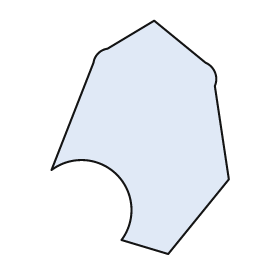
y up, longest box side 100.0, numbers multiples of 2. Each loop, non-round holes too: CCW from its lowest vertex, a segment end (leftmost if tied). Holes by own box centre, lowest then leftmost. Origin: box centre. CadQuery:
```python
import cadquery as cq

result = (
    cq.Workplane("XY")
    .moveTo(12.0, -50.0)
    .lineTo(38.0, -18.0)
    .lineTo(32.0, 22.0)
    .threePointArc((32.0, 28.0), (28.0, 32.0))
    .lineTo(6.0, 50.0)
    .lineTo(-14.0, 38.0)
    .threePointArc((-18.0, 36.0), (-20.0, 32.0))
    .lineTo(-38.0, -14.0)
    .threePointArc((-10.0, -16.0), (-8.0, -44.0))
    .close()
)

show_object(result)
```